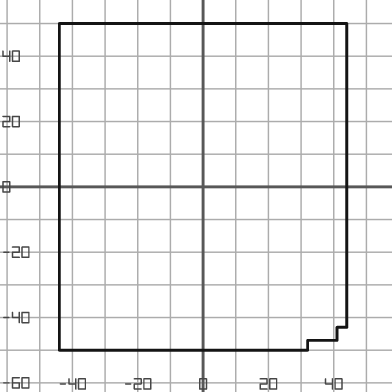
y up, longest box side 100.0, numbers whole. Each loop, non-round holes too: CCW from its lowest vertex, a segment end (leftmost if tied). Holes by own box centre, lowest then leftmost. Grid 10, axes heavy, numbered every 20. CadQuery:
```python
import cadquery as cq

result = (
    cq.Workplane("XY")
    .moveTo(-44.0, -50.0)
    .lineTo(32.0, -50.0)
    .lineTo(32.0, -47.0)
    .lineTo(41.0, -47.0)
    .lineTo(41.0, -43.0)
    .lineTo(44.0, -43.0)
    .lineTo(44.0, 50.0)
    .lineTo(-44.0, 50.0)
    .close()
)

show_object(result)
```